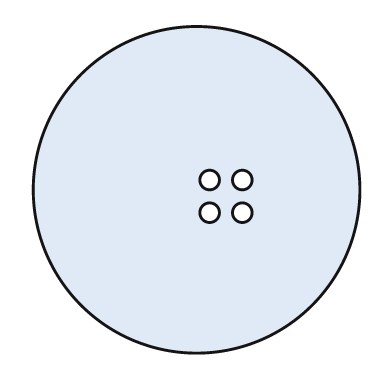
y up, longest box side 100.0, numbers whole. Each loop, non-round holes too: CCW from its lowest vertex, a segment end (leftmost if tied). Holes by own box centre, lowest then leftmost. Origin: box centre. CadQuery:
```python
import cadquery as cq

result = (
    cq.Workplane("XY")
    .moveTo(0.0, 0.0)
    .circle(50.0)
    .moveTo(4.0, -7.0)
    .circle(3.0)
    .moveTo(14.0, -7.0)
    .circle(3.0)
    .moveTo(4.0, 3.0)
    .circle(3.0)
    .moveTo(14.0, 3.0)
    .circle(3.0)
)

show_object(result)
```